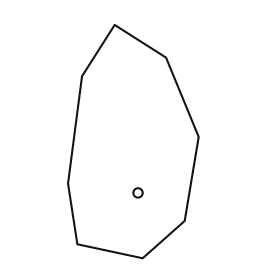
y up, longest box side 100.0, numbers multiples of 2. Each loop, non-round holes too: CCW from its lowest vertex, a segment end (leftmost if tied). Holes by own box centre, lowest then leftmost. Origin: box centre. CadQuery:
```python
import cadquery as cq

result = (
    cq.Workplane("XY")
    .moveTo(4.0, -50.0)
    .lineTo(22.0, -34.0)
    .lineTo(28.0, 2.0)
    .lineTo(14.0, 36.0)
    .lineTo(-8.0, 50.0)
    .lineTo(-22.0, 28.0)
    .lineTo(-28.0, -18.0)
    .lineTo(-24.0, -44.0)
    .close()
    .moveTo(2.0, -22.0)
    .circle(2.0)
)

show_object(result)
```